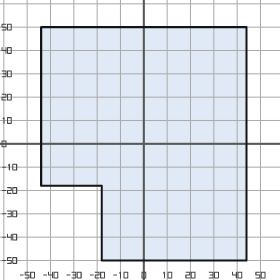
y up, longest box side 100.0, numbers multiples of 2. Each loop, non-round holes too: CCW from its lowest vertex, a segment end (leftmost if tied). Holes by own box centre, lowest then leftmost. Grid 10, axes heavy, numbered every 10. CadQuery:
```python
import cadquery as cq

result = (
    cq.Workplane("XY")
    .moveTo(-18.0, -50.0)
    .lineTo(44.0, -50.0)
    .lineTo(44.0, 50.0)
    .lineTo(-44.0, 50.0)
    .lineTo(-44.0, -18.0)
    .lineTo(-18.0, -18.0)
    .close()
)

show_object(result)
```